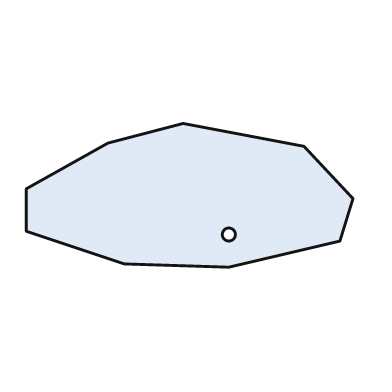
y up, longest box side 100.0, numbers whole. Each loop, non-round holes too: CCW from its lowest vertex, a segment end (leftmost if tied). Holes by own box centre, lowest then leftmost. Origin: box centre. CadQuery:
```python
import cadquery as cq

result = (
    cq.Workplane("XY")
    .moveTo(12.0, -22.0)
    .lineTo(46.0, -14.0)
    .lineTo(50.0, -1.0)
    .lineTo(35.0, 15.0)
    .lineTo(-2.0, 22.0)
    .lineTo(-25.0, 16.0)
    .lineTo(-50.0, 2.0)
    .lineTo(-50.0, -11.0)
    .lineTo(-20.0, -21.0)
    .close()
    .moveTo(12.0, -12.0)
    .circle(2.0)
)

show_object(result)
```